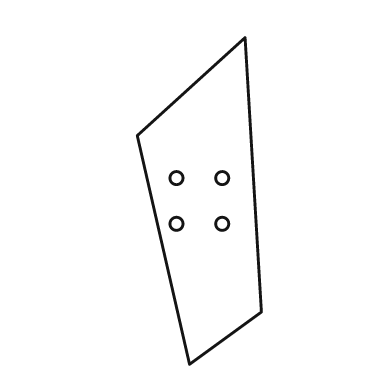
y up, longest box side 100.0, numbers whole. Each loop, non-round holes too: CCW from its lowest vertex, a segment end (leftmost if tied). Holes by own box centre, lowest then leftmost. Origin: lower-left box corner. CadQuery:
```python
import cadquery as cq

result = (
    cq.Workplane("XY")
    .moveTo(16.0, 0.0)
    .lineTo(38.0, 16.0)
    .lineTo(33.0, 100.0)
    .lineTo(0.0, 70.0)
    .close()
    .moveTo(12.0, 43.0)
    .circle(2.0)
    .moveTo(26.0, 43.0)
    .circle(2.0)
    .moveTo(12.0, 57.0)
    .circle(2.0)
    .moveTo(26.0, 57.0)
    .circle(2.0)
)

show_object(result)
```